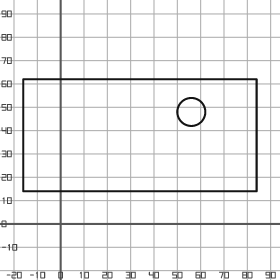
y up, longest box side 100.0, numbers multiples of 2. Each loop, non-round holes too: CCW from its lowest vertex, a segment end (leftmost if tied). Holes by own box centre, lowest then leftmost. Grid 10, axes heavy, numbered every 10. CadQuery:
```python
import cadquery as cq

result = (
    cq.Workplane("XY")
    .moveTo(-16.0, 14.0)
    .lineTo(84.0, 14.0)
    .lineTo(84.0, 62.0)
    .lineTo(-16.0, 62.0)
    .close()
    .moveTo(56.0, 48.0)
    .circle(6.0)
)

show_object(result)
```